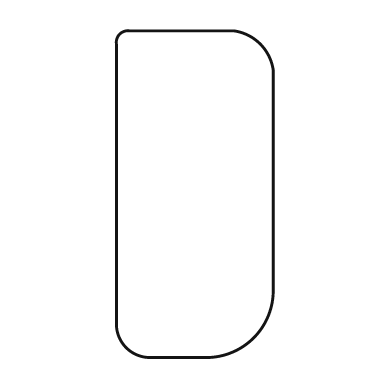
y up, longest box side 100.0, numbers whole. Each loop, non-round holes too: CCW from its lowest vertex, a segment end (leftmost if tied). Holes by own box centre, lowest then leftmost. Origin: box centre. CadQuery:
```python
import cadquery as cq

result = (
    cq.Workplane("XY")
    .moveTo(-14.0, -50.0)
    .lineTo(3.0, -50.0)
    .threePointArc((18.0, -44.0), (24.0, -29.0))
    .lineTo(24.0, 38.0)
    .threePointArc((20.0, 46.0), (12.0, 50.0))
    .lineTo(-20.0, 50.0)
    .threePointArc((-23.0, 49.0), (-24.0, 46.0))
    .lineTo(-24.0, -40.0)
    .threePointArc((-21.0, -47.0), (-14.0, -50.0))
    .close()
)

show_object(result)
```